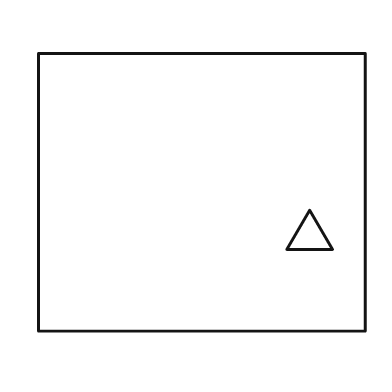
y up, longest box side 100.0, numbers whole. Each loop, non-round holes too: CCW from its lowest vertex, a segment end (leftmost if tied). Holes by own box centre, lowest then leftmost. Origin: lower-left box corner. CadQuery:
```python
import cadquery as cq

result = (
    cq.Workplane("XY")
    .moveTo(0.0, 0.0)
    .lineTo(100.0, 0.0)
    .lineTo(100.0, 85.0)
    .lineTo(0.0, 85.0)
    .close()
    .moveTo(76.0, 25.0)
    .lineTo(90.0, 25.0)
    .lineTo(83.0, 37.0)
    .close()
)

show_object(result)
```